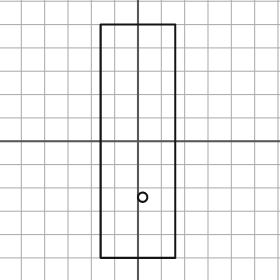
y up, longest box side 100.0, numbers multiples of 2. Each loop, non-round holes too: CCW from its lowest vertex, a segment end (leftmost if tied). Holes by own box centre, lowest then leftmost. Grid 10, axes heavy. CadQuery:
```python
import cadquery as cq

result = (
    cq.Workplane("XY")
    .moveTo(-16.0, -50.0)
    .lineTo(16.0, -50.0)
    .lineTo(16.0, 50.0)
    .lineTo(-16.0, 50.0)
    .close()
    .moveTo(2.0, -24.0)
    .circle(2.0)
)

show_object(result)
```